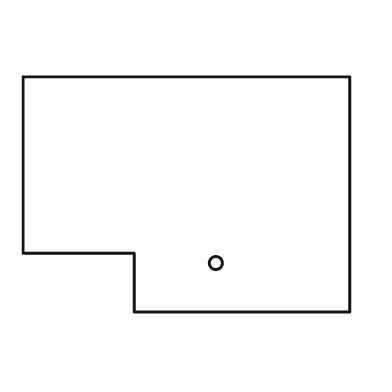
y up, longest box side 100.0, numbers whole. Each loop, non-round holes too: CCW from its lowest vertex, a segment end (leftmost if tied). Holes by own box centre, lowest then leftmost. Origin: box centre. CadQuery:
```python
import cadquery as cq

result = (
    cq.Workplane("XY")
    .moveTo(-16.0, -36.0)
    .lineTo(50.0, -36.0)
    .lineTo(50.0, 36.0)
    .lineTo(-50.0, 36.0)
    .lineTo(-50.0, -18.0)
    .lineTo(-16.0, -18.0)
    .close()
    .moveTo(9.0, -21.0)
    .circle(2.0)
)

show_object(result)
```